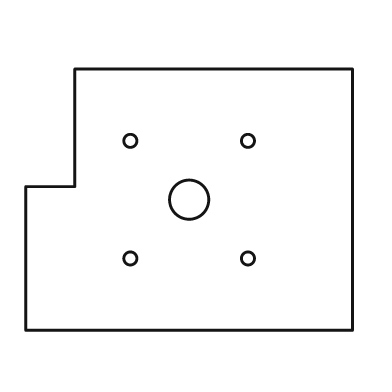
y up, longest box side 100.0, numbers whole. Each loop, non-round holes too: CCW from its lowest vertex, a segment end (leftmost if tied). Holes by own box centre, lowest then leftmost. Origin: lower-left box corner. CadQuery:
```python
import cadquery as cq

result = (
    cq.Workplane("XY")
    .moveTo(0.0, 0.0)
    .lineTo(100.0, 0.0)
    .lineTo(100.0, 80.0)
    .lineTo(15.0, 80.0)
    .lineTo(15.0, 44.0)
    .lineTo(0.0, 44.0)
    .close()
    .moveTo(32.0, 22.0)
    .circle(2.0)
    .moveTo(68.0, 22.0)
    .circle(2.0)
    .moveTo(50.0, 40.0)
    .circle(6.0)
    .moveTo(32.0, 58.0)
    .circle(2.0)
    .moveTo(68.0, 58.0)
    .circle(2.0)
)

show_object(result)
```